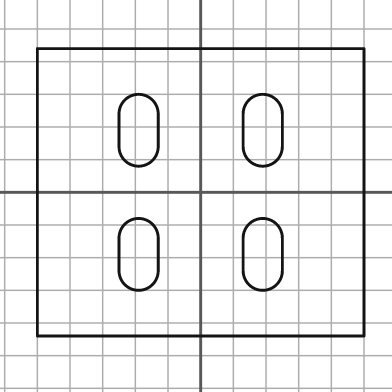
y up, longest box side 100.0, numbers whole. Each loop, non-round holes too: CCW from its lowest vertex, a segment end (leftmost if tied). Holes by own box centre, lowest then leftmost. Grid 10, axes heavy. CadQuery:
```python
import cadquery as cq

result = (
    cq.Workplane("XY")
    .moveTo(-50.0, -44.0)
    .lineTo(50.0, -44.0)
    .lineTo(50.0, 44.0)
    .lineTo(-50.0, 44.0)
    .close()
    .moveTo(-25.0, -24.0)
    .threePointArc((-19.0, -30.0), (-13.0, -24.0))
    .lineTo(-13.0, -14.0)
    .threePointArc((-19.0, -8.0), (-25.0, -14.0))
    .close()
    .moveTo(13.0, -24.0)
    .threePointArc((19.0, -30.0), (25.0, -24.0))
    .lineTo(25.0, -14.0)
    .threePointArc((19.0, -8.0), (13.0, -14.0))
    .close()
    .moveTo(-25.0, 14.0)
    .threePointArc((-19.0, 8.0), (-13.0, 14.0))
    .lineTo(-13.0, 24.0)
    .threePointArc((-19.0, 30.0), (-25.0, 24.0))
    .close()
    .moveTo(13.0, 14.0)
    .threePointArc((19.0, 8.0), (25.0, 14.0))
    .lineTo(25.0, 24.0)
    .threePointArc((19.0, 30.0), (13.0, 24.0))
    .close()
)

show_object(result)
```